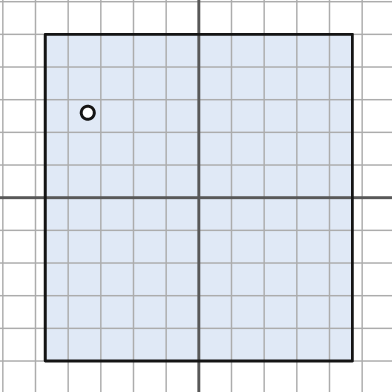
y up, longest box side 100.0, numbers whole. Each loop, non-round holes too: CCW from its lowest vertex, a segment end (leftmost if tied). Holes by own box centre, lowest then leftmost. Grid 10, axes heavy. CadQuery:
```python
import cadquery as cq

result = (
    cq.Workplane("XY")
    .moveTo(-47.0, -50.0)
    .lineTo(47.0, -50.0)
    .lineTo(47.0, 50.0)
    .lineTo(-47.0, 50.0)
    .close()
    .moveTo(-34.0, 26.0)
    .circle(2.0)
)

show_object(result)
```